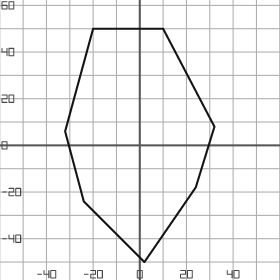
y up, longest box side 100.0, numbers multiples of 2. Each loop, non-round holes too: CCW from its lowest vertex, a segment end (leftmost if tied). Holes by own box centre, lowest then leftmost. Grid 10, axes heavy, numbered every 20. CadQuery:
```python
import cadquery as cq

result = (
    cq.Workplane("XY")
    .moveTo(2.0, -50.0)
    .lineTo(24.0, -18.0)
    .lineTo(32.0, 8.0)
    .lineTo(10.0, 50.0)
    .lineTo(-20.0, 50.0)
    .lineTo(-32.0, 6.0)
    .lineTo(-24.0, -24.0)
    .close()
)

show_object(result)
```